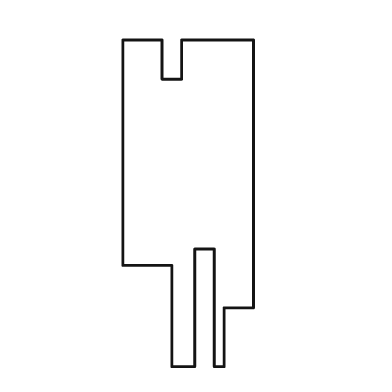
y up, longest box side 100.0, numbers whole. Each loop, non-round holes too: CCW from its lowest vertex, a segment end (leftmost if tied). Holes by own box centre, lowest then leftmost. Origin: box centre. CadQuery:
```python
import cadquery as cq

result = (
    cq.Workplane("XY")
    .moveTo(-5.0, -50.0)
    .lineTo(2.0, -50.0)
    .lineTo(2.0, -14.0)
    .lineTo(8.0, -14.0)
    .lineTo(8.0, -50.0)
    .lineTo(11.0, -50.0)
    .lineTo(11.0, -32.0)
    .lineTo(20.0, -32.0)
    .lineTo(20.0, 50.0)
    .lineTo(-2.0, 50.0)
    .lineTo(-2.0, 38.0)
    .lineTo(-8.0, 38.0)
    .lineTo(-8.0, 50.0)
    .lineTo(-20.0, 50.0)
    .lineTo(-20.0, -19.0)
    .lineTo(-5.0, -19.0)
    .close()
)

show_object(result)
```